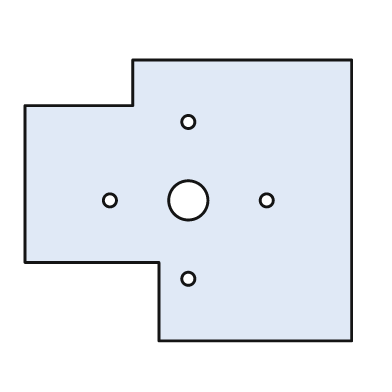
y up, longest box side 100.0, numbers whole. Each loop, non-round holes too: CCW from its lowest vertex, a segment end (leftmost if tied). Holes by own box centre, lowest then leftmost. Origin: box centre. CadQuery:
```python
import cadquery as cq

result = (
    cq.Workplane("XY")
    .moveTo(-9.0, -43.0)
    .lineTo(50.0, -43.0)
    .lineTo(50.0, 43.0)
    .lineTo(-17.0, 43.0)
    .lineTo(-17.0, 29.0)
    .lineTo(-50.0, 29.0)
    .lineTo(-50.0, -19.0)
    .lineTo(-9.0, -19.0)
    .close()
    .moveTo(0.0, -24.0)
    .circle(2.0)
    .moveTo(-24.0, 0.0)
    .circle(2.0)
    .moveTo(0.0, 0.0)
    .circle(6.0)
    .moveTo(24.0, 0.0)
    .circle(2.0)
    .moveTo(0.0, 24.0)
    .circle(2.0)
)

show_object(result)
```